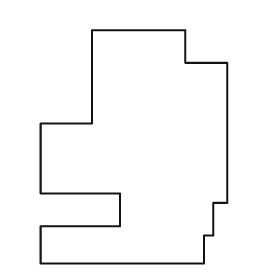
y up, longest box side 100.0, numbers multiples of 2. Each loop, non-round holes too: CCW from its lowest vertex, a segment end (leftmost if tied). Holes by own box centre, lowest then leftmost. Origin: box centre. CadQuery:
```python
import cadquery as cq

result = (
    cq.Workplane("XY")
    .moveTo(-40.0, -50.0)
    .lineTo(30.0, -50.0)
    .lineTo(30.0, -38.0)
    .lineTo(34.0, -38.0)
    .lineTo(34.0, -24.0)
    .lineTo(40.0, -24.0)
    .lineTo(40.0, 36.0)
    .lineTo(22.0, 36.0)
    .lineTo(22.0, 50.0)
    .lineTo(-18.0, 50.0)
    .lineTo(-18.0, 10.0)
    .lineTo(-40.0, 10.0)
    .lineTo(-40.0, -20.0)
    .lineTo(-6.0, -20.0)
    .lineTo(-6.0, -34.0)
    .lineTo(-40.0, -34.0)
    .close()
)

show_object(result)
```